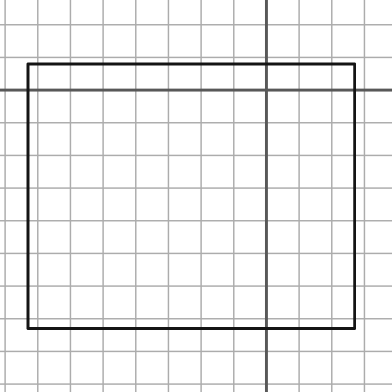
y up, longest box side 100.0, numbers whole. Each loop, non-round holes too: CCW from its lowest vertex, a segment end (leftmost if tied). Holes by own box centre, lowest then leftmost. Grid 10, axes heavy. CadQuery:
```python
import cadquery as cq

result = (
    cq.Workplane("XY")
    .moveTo(-73.0, -73.0)
    .lineTo(27.0, -73.0)
    .lineTo(27.0, 8.0)
    .lineTo(-73.0, 8.0)
    .close()
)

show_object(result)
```